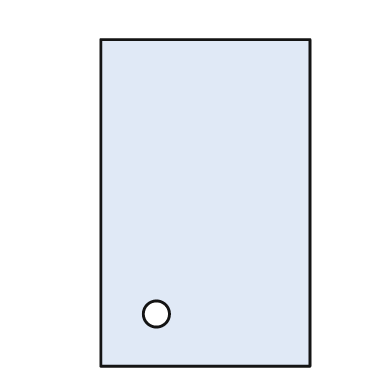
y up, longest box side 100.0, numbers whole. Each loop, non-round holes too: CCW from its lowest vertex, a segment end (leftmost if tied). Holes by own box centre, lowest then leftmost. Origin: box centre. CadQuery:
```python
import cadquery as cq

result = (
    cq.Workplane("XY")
    .moveTo(-32.0, -50.0)
    .lineTo(32.0, -50.0)
    .lineTo(32.0, 50.0)
    .lineTo(-32.0, 50.0)
    .close()
    .moveTo(-15.0, -34.0)
    .circle(4.0)
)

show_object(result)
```